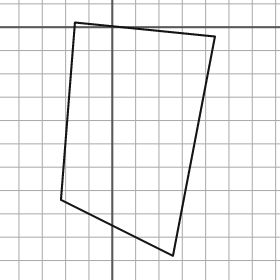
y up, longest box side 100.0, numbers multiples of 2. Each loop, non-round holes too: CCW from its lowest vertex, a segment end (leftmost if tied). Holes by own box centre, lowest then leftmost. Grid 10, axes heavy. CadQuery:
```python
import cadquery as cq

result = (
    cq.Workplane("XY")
    .moveTo(26.0, -98.0)
    .lineTo(44.0, -4.0)
    .lineTo(-16.0, 2.0)
    .lineTo(-22.0, -74.0)
    .close()
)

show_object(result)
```